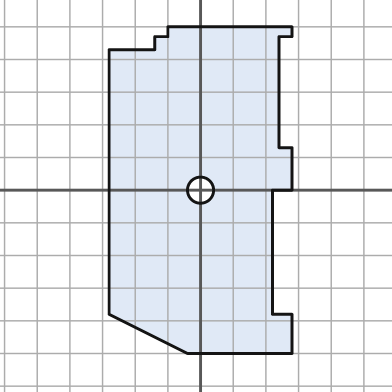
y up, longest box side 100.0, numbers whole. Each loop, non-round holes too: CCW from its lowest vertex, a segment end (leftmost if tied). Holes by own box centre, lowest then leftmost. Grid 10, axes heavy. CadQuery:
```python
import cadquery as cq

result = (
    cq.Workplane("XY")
    .moveTo(-4.0, -50.0)
    .lineTo(28.0, -50.0)
    .lineTo(28.0, -38.0)
    .lineTo(22.0, -38.0)
    .lineTo(22.0, 0.0)
    .lineTo(28.0, 0.0)
    .lineTo(28.0, 13.0)
    .lineTo(24.0, 13.0)
    .lineTo(24.0, 47.0)
    .lineTo(28.0, 47.0)
    .lineTo(28.0, 50.0)
    .lineTo(-10.0, 50.0)
    .lineTo(-10.0, 47.0)
    .lineTo(-14.0, 47.0)
    .lineTo(-14.0, 43.0)
    .lineTo(-28.0, 43.0)
    .lineTo(-28.0, -38.0)
    .close()
    .moveTo(0.0, 0.0)
    .circle(4.0)
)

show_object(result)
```